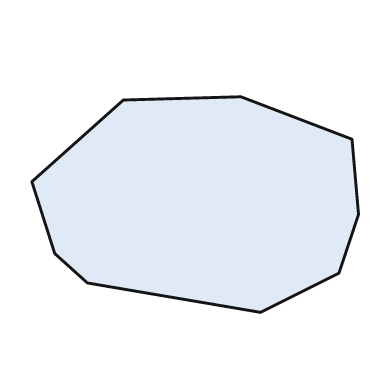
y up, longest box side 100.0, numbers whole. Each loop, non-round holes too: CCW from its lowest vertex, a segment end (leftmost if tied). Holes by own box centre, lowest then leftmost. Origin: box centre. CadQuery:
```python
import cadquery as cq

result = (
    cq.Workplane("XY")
    .moveTo(20.0, -33.0)
    .lineTo(44.0, -21.0)
    .lineTo(50.0, -3.0)
    .lineTo(48.0, 20.0)
    .lineTo(14.0, 33.0)
    .lineTo(-22.0, 32.0)
    .lineTo(-50.0, 7.0)
    .lineTo(-43.0, -15.0)
    .lineTo(-33.0, -24.0)
    .close()
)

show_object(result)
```